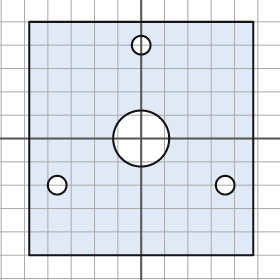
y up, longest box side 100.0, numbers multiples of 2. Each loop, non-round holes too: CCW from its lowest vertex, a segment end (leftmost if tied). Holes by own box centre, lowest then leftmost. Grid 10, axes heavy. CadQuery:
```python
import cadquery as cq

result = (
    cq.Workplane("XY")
    .moveTo(-48.0, -50.0)
    .lineTo(48.0, -50.0)
    .lineTo(48.0, 50.0)
    .lineTo(-48.0, 50.0)
    .close()
    .moveTo(-36.0, -20.0)
    .circle(4.0)
    .moveTo(36.0, -20.0)
    .circle(4.0)
    .moveTo(0.0, 0.0)
    .circle(12.0)
    .moveTo(0.0, 40.0)
    .circle(4.0)
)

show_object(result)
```